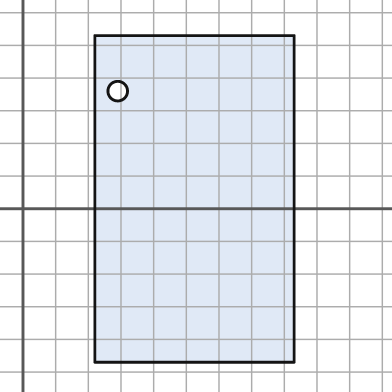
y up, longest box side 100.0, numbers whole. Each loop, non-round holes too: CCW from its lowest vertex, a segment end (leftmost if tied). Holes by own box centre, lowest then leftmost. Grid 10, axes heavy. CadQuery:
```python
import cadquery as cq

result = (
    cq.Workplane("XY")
    .moveTo(22.0, -47.0)
    .lineTo(83.0, -47.0)
    .lineTo(83.0, 53.0)
    .lineTo(22.0, 53.0)
    .close()
    .moveTo(29.0, 36.0)
    .circle(3.0)
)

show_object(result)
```